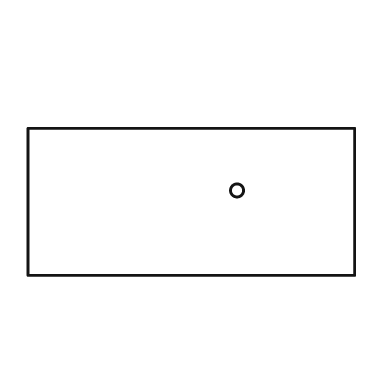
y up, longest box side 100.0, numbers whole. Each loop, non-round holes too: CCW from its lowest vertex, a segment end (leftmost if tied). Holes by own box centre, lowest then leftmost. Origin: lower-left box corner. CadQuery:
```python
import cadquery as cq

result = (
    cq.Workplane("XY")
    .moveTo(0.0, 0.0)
    .lineTo(100.0, 0.0)
    .lineTo(100.0, 45.0)
    .lineTo(0.0, 45.0)
    .close()
    .moveTo(64.0, 26.0)
    .circle(2.0)
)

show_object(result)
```